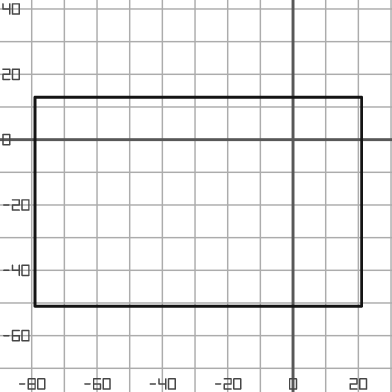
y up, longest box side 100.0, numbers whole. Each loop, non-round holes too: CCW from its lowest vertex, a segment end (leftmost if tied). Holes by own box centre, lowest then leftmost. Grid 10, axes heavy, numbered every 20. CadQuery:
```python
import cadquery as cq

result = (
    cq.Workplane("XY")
    .moveTo(-79.0, -51.0)
    .lineTo(21.0, -51.0)
    .lineTo(21.0, 13.0)
    .lineTo(-79.0, 13.0)
    .close()
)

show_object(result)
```